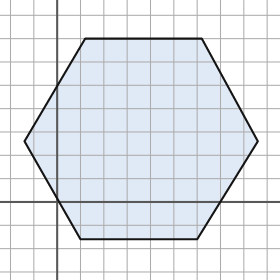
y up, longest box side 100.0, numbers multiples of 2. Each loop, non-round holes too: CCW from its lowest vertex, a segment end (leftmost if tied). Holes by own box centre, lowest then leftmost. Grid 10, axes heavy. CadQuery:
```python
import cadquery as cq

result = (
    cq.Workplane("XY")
    .moveTo(10.0, -16.0)
    .lineTo(60.0, -16.0)
    .lineTo(86.0, 26.0)
    .lineTo(62.0, 70.0)
    .lineTo(12.0, 70.0)
    .lineTo(-14.0, 26.0)
    .close()
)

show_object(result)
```